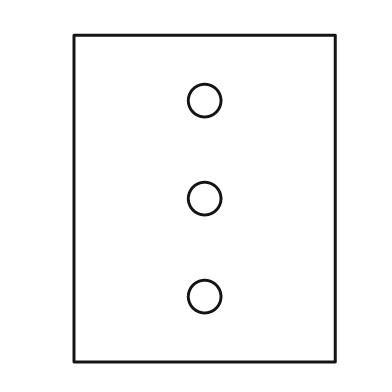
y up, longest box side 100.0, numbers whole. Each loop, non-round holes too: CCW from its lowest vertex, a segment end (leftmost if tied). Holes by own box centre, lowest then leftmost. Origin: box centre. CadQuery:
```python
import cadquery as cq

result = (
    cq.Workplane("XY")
    .moveTo(-40.0, -50.0)
    .lineTo(40.0, -50.0)
    .lineTo(40.0, 50.0)
    .lineTo(-40.0, 50.0)
    .close()
    .moveTo(0.0, -30.0)
    .circle(5.0)
    .moveTo(0.0, 0.0)
    .circle(5.0)
    .moveTo(0.0, 30.0)
    .circle(5.0)
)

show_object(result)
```